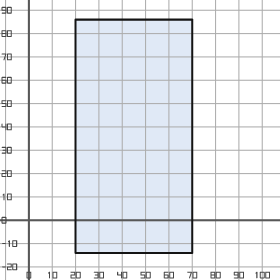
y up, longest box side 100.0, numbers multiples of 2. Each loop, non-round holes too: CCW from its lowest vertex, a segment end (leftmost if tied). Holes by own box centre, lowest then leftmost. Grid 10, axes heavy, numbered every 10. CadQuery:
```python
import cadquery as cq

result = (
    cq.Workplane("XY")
    .moveTo(20.0, -14.0)
    .lineTo(70.0, -14.0)
    .lineTo(70.0, 86.0)
    .lineTo(20.0, 86.0)
    .close()
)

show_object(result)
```